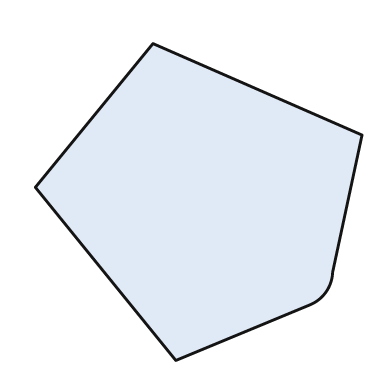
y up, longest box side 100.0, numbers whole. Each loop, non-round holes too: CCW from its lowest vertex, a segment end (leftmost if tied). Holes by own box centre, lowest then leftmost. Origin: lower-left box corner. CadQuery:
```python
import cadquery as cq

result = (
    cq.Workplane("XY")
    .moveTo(43.0, 0.0)
    .lineTo(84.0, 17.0)
    .threePointArc((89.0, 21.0), (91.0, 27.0))
    .lineTo(100.0, 69.0)
    .lineTo(36.0, 97.0)
    .lineTo(0.0, 53.0)
    .close()
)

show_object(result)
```